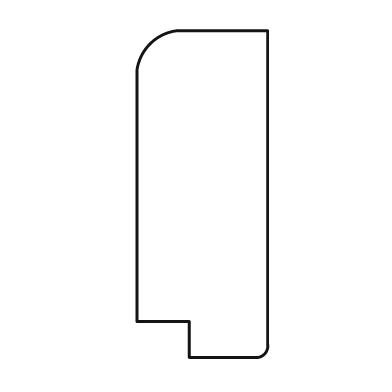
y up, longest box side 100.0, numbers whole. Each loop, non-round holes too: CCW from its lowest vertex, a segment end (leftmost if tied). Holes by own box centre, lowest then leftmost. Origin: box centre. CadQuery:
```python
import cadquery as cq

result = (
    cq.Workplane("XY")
    .moveTo(-4.0, -50.0)
    .lineTo(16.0, -50.0)
    .threePointArc((19.0, -49.0), (20.0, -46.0))
    .lineTo(20.0, 50.0)
    .lineTo(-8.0, 50.0)
    .threePointArc((-16.0, 46.0), (-20.0, 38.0))
    .lineTo(-20.0, -39.0)
    .lineTo(-4.0, -39.0)
    .close()
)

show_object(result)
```